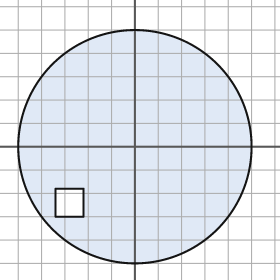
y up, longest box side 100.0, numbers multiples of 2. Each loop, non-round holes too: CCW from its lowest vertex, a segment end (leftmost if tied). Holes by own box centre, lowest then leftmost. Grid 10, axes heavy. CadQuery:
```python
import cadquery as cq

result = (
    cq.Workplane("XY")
    .moveTo(0.0, 0.0)
    .circle(50.0)
    .moveTo(-34.0, -30.0)
    .lineTo(-22.0, -30.0)
    .lineTo(-22.0, -18.0)
    .lineTo(-34.0, -18.0)
    .close()
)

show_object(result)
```